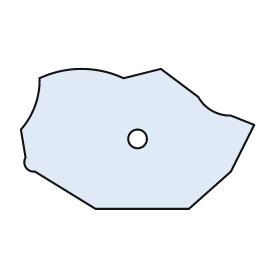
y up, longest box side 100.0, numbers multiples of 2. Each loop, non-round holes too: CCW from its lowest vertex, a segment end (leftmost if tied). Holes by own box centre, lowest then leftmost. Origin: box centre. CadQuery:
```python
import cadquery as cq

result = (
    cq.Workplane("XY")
    .moveTo(-18.0, -30.0)
    .lineTo(22.0, -30.0)
    .lineTo(40.0, -14.0)
    .lineTo(50.0, 6.0)
    .lineTo(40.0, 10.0)
    .threePointArc((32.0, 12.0), (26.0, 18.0))
    .lineTo(10.0, 30.0)
    .lineTo(-6.0, 26.0)
    .threePointArc((-24.0, 30.0), (-42.0, 26.0))
    .threePointArc((-44.0, 14.0), (-50.0, 4.0))
    .lineTo(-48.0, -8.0)
    .threePointArc((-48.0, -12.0), (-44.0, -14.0))
    .close()
    .moveTo(0.0, 0.0)
    .circle(4.0)
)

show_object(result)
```